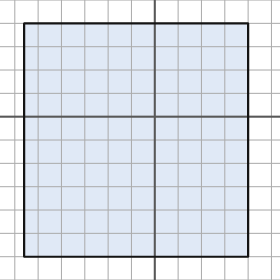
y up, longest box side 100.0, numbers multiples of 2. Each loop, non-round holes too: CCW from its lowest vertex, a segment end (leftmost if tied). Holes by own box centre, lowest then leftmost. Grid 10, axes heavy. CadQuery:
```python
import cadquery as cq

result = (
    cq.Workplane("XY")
    .moveTo(-56.0, -60.0)
    .lineTo(40.0, -60.0)
    .lineTo(40.0, 40.0)
    .lineTo(-56.0, 40.0)
    .close()
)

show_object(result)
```